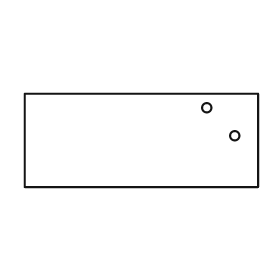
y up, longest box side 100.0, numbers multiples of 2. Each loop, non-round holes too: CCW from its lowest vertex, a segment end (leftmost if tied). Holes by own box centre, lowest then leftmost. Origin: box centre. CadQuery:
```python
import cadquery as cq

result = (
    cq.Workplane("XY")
    .moveTo(-50.0, -20.0)
    .lineTo(50.0, -20.0)
    .lineTo(50.0, 20.0)
    .lineTo(-50.0, 20.0)
    .close()
    .moveTo(40.0, 2.0)
    .circle(2.0)
    .moveTo(28.0, 14.0)
    .circle(2.0)
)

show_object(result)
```